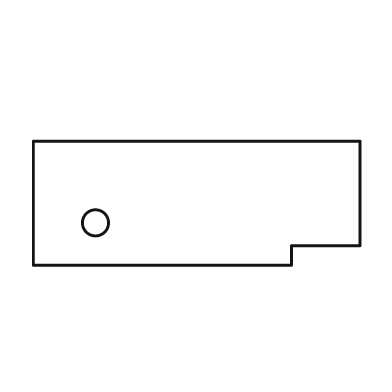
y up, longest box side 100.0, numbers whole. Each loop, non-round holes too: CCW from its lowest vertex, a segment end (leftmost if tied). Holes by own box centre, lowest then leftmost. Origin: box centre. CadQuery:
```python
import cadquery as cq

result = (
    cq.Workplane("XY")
    .moveTo(-50.0, -19.0)
    .lineTo(29.0, -19.0)
    .lineTo(29.0, -13.0)
    .lineTo(50.0, -13.0)
    .lineTo(50.0, 19.0)
    .lineTo(-50.0, 19.0)
    .close()
    .moveTo(-31.0, -6.0)
    .circle(4.0)
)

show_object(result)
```